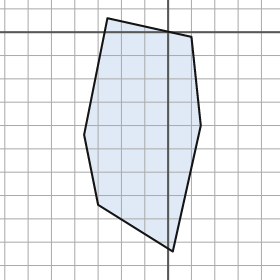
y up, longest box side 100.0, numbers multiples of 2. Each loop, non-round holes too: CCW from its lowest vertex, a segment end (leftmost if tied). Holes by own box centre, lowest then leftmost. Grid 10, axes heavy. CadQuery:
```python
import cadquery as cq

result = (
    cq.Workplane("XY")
    .moveTo(2.0, -94.0)
    .lineTo(14.0, -40.0)
    .lineTo(10.0, -2.0)
    .lineTo(-26.0, 6.0)
    .lineTo(-36.0, -44.0)
    .lineTo(-30.0, -74.0)
    .close()
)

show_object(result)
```